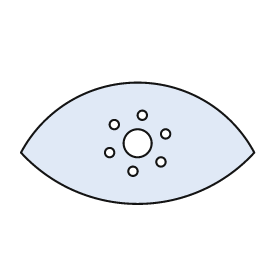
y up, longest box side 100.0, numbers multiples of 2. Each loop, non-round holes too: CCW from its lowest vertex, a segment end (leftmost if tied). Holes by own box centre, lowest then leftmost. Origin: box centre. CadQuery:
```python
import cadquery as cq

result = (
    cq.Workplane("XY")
    .moveTo(-50.0, -4.0)
    .threePointArc((0.0, -26.0), (50.0, -4.0))
    .threePointArc((0.0, 26.0), (-50.0, -4.0))
    .close()
    .moveTo(-2.0, -12.0)
    .circle(2.0)
    .moveTo(10.0, -8.0)
    .circle(2.0)
    .moveTo(-12.0, -4.0)
    .circle(2.0)
    .moveTo(0.0, 0.0)
    .circle(6.0)
    .moveTo(12.0, 4.0)
    .circle(2.0)
    .moveTo(-10.0, 8.0)
    .circle(2.0)
    .moveTo(2.0, 12.0)
    .circle(2.0)
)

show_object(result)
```